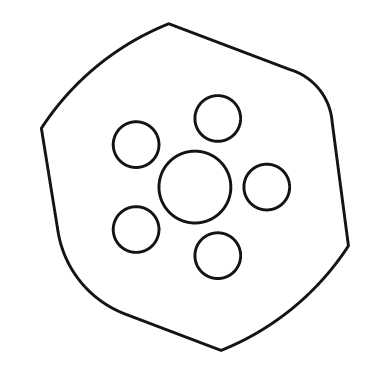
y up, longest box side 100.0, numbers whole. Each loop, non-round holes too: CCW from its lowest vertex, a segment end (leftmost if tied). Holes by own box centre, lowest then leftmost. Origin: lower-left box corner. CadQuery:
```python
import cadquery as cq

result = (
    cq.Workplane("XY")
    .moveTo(55.0, 0.0)
    .threePointArc((77.0, 13.0), (94.0, 32.0))
    .lineTo(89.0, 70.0)
    .threePointArc((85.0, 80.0), (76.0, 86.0))
    .lineTo(39.0, 100.0)
    .threePointArc((17.0, 87.0), (0.0, 68.0))
    .lineTo(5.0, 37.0)
    .threePointArc((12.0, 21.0), (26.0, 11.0))
    .close()
    .moveTo(54.0, 29.0)
    .circle(7.0)
    .moveTo(29.0, 37.0)
    .circle(7.0)
    .moveTo(47.0, 50.0)
    .circle(11.0)
    .moveTo(69.0, 50.0)
    .circle(7.0)
    .moveTo(29.0, 63.0)
    .circle(7.0)
    .moveTo(54.0, 71.0)
    .circle(7.0)
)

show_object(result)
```